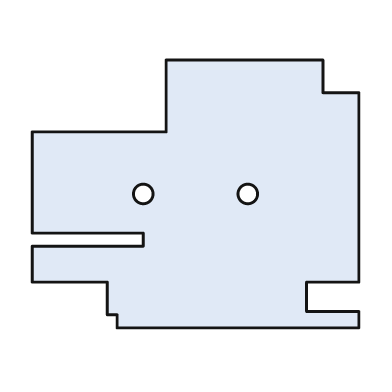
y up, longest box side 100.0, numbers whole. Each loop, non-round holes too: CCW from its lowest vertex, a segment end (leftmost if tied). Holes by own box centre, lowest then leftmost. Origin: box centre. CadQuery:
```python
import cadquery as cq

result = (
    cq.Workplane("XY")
    .moveTo(-24.0, -41.0)
    .lineTo(50.0, -41.0)
    .lineTo(50.0, -36.0)
    .lineTo(34.0, -36.0)
    .lineTo(34.0, -27.0)
    .lineTo(50.0, -27.0)
    .lineTo(50.0, 31.0)
    .lineTo(39.0, 31.0)
    .lineTo(39.0, 41.0)
    .lineTo(-9.0, 41.0)
    .lineTo(-9.0, 19.0)
    .lineTo(-50.0, 19.0)
    .lineTo(-50.0, -12.0)
    .lineTo(-16.0, -12.0)
    .lineTo(-16.0, -16.0)
    .lineTo(-50.0, -16.0)
    .lineTo(-50.0, -27.0)
    .lineTo(-27.0, -27.0)
    .lineTo(-27.0, -37.0)
    .lineTo(-24.0, -37.0)
    .close()
    .moveTo(-16.0, 0.0)
    .circle(3.0)
    .moveTo(16.0, 0.0)
    .circle(3.0)
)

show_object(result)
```